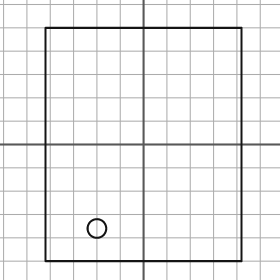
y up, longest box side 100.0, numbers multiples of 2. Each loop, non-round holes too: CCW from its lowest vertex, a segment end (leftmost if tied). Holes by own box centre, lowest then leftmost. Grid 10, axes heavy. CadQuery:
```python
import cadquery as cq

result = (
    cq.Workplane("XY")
    .moveTo(-42.0, -50.0)
    .lineTo(42.0, -50.0)
    .lineTo(42.0, 50.0)
    .lineTo(-42.0, 50.0)
    .close()
    .moveTo(-20.0, -36.0)
    .circle(4.0)
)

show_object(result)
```